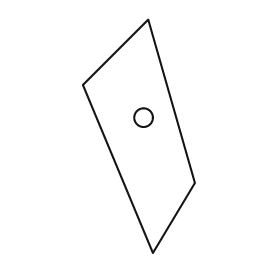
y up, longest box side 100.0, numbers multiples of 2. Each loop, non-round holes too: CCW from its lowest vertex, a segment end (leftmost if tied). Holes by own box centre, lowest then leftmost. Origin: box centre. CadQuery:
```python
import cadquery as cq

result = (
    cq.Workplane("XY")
    .moveTo(6.0, -50.0)
    .lineTo(24.0, -20.0)
    .lineTo(4.0, 50.0)
    .lineTo(-24.0, 22.0)
    .close()
    .moveTo(2.0, 8.0)
    .circle(4.0)
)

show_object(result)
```